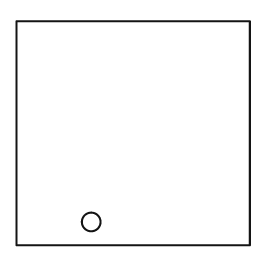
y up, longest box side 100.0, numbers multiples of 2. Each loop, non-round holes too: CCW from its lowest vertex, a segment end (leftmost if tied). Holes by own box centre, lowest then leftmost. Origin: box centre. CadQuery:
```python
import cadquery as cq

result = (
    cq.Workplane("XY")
    .moveTo(-50.0, -48.0)
    .lineTo(50.0, -48.0)
    .lineTo(50.0, 48.0)
    .lineTo(-50.0, 48.0)
    .close()
    .moveTo(-18.0, -38.0)
    .circle(4.0)
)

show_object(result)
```